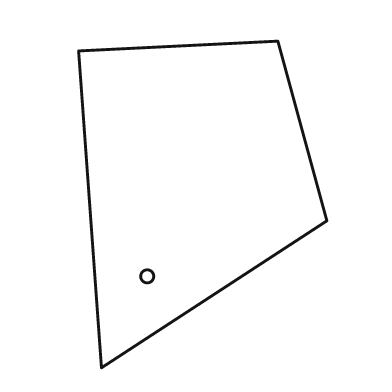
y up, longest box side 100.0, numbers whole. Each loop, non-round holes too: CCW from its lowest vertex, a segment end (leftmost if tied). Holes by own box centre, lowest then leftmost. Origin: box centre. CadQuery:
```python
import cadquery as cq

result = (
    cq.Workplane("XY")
    .moveTo(-31.0, -50.0)
    .lineTo(38.0, -5.0)
    .lineTo(23.0, 50.0)
    .lineTo(-38.0, 47.0)
    .close()
    .moveTo(-17.0, -22.0)
    .circle(2.0)
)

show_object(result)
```